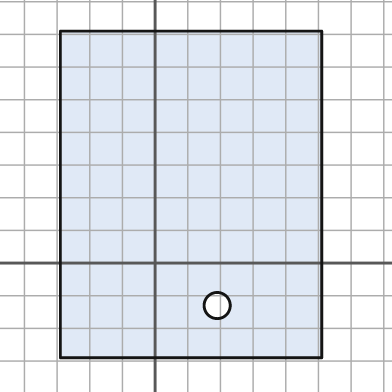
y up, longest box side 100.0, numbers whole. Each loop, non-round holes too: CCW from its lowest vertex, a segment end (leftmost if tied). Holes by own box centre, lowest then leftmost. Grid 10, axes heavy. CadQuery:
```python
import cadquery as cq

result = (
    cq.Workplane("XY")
    .moveTo(-29.0, -29.0)
    .lineTo(51.0, -29.0)
    .lineTo(51.0, 71.0)
    .lineTo(-29.0, 71.0)
    .close()
    .moveTo(19.0, -13.0)
    .circle(4.0)
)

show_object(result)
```